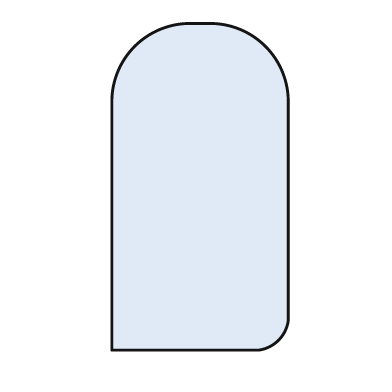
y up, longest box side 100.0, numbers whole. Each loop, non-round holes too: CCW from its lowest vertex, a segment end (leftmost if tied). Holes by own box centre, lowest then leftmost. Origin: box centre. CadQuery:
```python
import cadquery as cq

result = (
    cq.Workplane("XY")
    .moveTo(-27.0, -50.0)
    .lineTo(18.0, -50.0)
    .threePointArc((24.0, -47.0), (27.0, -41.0))
    .lineTo(27.0, 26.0)
    .threePointArc((20.0, 43.0), (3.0, 50.0))
    .lineTo(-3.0, 50.0)
    .threePointArc((-20.0, 43.0), (-27.0, 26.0))
    .close()
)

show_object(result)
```